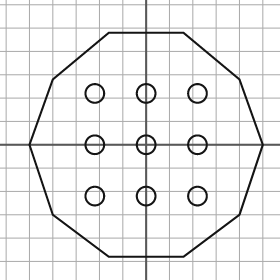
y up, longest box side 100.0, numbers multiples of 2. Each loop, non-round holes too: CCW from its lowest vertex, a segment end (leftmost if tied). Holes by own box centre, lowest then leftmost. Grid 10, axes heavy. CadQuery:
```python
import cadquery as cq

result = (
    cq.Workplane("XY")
    .moveTo(-16.0, -48.0)
    .lineTo(16.0, -48.0)
    .lineTo(40.0, -30.0)
    .lineTo(50.0, 0.0)
    .lineTo(40.0, 28.0)
    .lineTo(16.0, 48.0)
    .lineTo(-16.0, 48.0)
    .lineTo(-40.0, 28.0)
    .lineTo(-50.0, 0.0)
    .lineTo(-40.0, -30.0)
    .close()
    .moveTo(-22.0, -22.0)
    .circle(4.0)
    .moveTo(0.0, -22.0)
    .circle(4.0)
    .moveTo(22.0, -22.0)
    .circle(4.0)
    .moveTo(-22.0, 0.0)
    .circle(4.0)
    .moveTo(0.0, 0.0)
    .circle(4.0)
    .moveTo(22.0, 0.0)
    .circle(4.0)
    .moveTo(-22.0, 22.0)
    .circle(4.0)
    .moveTo(0.0, 22.0)
    .circle(4.0)
    .moveTo(22.0, 22.0)
    .circle(4.0)
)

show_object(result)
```